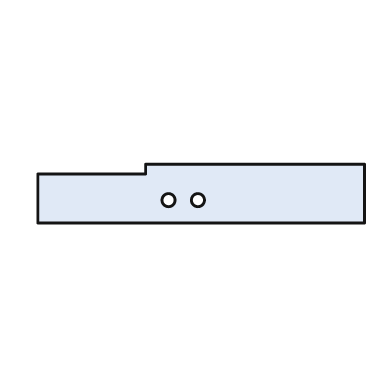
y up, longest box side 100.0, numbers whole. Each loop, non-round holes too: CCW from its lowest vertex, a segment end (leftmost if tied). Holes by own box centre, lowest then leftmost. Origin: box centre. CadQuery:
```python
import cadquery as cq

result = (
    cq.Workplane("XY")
    .moveTo(-50.0, -9.0)
    .lineTo(50.0, -9.0)
    .lineTo(50.0, 9.0)
    .lineTo(-17.0, 9.0)
    .lineTo(-17.0, 6.0)
    .lineTo(-50.0, 6.0)
    .close()
    .moveTo(-10.0, -2.0)
    .circle(2.0)
    .moveTo(-1.0, -2.0)
    .circle(2.0)
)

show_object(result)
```